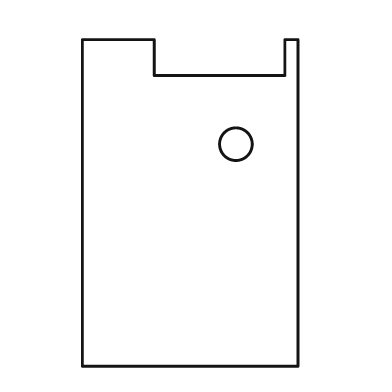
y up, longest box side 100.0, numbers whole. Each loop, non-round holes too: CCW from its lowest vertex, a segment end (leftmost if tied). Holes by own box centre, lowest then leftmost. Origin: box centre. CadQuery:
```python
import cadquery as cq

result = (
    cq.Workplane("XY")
    .moveTo(-33.0, -50.0)
    .lineTo(33.0, -50.0)
    .lineTo(33.0, 50.0)
    .lineTo(29.0, 50.0)
    .lineTo(29.0, 39.0)
    .lineTo(-11.0, 39.0)
    .lineTo(-11.0, 50.0)
    .lineTo(-33.0, 50.0)
    .close()
    .moveTo(14.0, 18.0)
    .circle(5.0)
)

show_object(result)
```